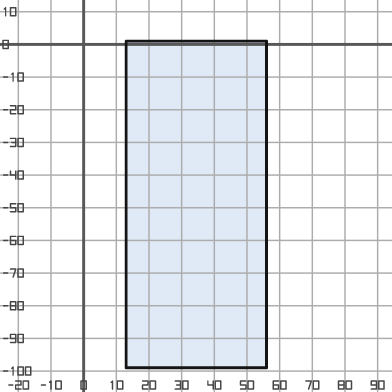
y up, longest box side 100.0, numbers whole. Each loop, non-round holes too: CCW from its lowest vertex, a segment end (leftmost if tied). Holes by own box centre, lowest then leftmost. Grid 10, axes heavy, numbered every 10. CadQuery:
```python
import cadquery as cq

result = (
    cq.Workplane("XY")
    .moveTo(13.0, -99.0)
    .lineTo(56.0, -99.0)
    .lineTo(56.0, 1.0)
    .lineTo(13.0, 1.0)
    .close()
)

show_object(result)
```